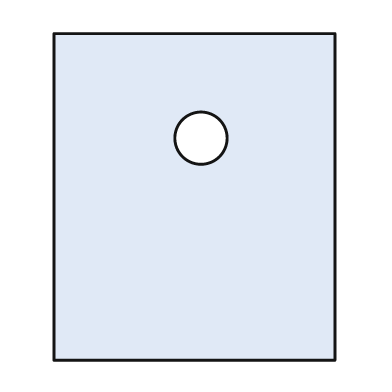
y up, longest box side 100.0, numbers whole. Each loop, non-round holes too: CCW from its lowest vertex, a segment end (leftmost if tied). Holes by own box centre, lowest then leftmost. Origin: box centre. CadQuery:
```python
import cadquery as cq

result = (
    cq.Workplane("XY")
    .moveTo(-43.0, -50.0)
    .lineTo(43.0, -50.0)
    .lineTo(43.0, 50.0)
    .lineTo(-43.0, 50.0)
    .close()
    .moveTo(2.0, 18.0)
    .circle(8.0)
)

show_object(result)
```